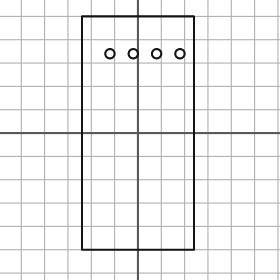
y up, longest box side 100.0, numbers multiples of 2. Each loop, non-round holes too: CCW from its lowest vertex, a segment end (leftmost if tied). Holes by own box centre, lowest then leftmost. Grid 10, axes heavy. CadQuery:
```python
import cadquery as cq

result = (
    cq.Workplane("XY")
    .moveTo(-24.0, -50.0)
    .lineTo(24.0, -50.0)
    .lineTo(24.0, 50.0)
    .lineTo(-24.0, 50.0)
    .close()
    .moveTo(-12.0, 34.0)
    .circle(2.0)
    .moveTo(-2.0, 34.0)
    .circle(2.0)
    .moveTo(8.0, 34.0)
    .circle(2.0)
    .moveTo(18.0, 34.0)
    .circle(2.0)
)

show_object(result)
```